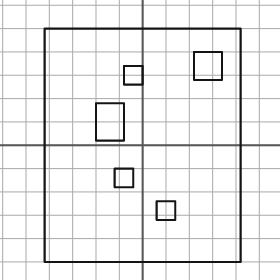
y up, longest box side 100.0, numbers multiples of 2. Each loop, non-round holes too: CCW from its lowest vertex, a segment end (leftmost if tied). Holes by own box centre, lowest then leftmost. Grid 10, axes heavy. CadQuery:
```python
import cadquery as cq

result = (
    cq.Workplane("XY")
    .moveTo(-42.0, -50.0)
    .lineTo(42.0, -50.0)
    .lineTo(42.0, 50.0)
    .lineTo(-42.0, 50.0)
    .close()
    .moveTo(6.0, -32.0)
    .lineTo(14.0, -32.0)
    .lineTo(14.0, -24.0)
    .lineTo(6.0, -24.0)
    .close()
    .moveTo(-12.0, -18.0)
    .lineTo(-4.0, -18.0)
    .lineTo(-4.0, -10.0)
    .lineTo(-12.0, -10.0)
    .close()
    .moveTo(-20.0, 2.0)
    .lineTo(-8.0, 2.0)
    .lineTo(-8.0, 18.0)
    .lineTo(-20.0, 18.0)
    .close()
    .moveTo(-8.0, 26.0)
    .lineTo(0.0, 26.0)
    .lineTo(0.0, 34.0)
    .lineTo(-8.0, 34.0)
    .close()
    .moveTo(22.0, 28.0)
    .lineTo(34.0, 28.0)
    .lineTo(34.0, 40.0)
    .lineTo(22.0, 40.0)
    .close()
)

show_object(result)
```